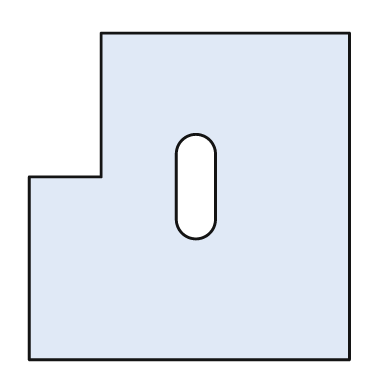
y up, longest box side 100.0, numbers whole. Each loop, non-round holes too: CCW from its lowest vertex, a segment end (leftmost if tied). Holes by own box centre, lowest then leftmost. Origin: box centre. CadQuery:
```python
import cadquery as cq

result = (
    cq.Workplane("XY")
    .moveTo(-49.0, -50.0)
    .lineTo(49.0, -50.0)
    .lineTo(49.0, 50.0)
    .lineTo(-27.0, 50.0)
    .lineTo(-27.0, 6.0)
    .lineTo(-49.0, 6.0)
    .close()
    .moveTo(-4.0, -7.0)
    .threePointArc((2.0, -13.0), (8.0, -7.0))
    .lineTo(8.0, 13.0)
    .threePointArc((2.0, 19.0), (-4.0, 13.0))
    .close()
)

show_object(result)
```